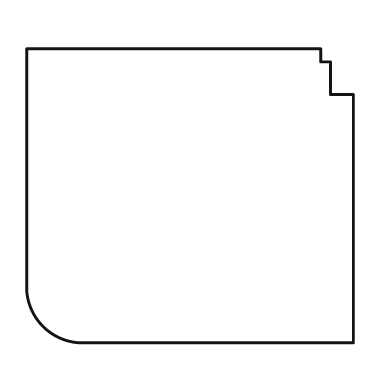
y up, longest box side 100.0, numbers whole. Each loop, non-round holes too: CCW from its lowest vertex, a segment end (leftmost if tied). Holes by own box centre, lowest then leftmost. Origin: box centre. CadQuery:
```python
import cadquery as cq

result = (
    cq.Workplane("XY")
    .moveTo(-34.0, -45.0)
    .lineTo(50.0, -45.0)
    .lineTo(50.0, 31.0)
    .lineTo(43.0, 31.0)
    .lineTo(43.0, 41.0)
    .lineTo(40.0, 41.0)
    .lineTo(40.0, 45.0)
    .lineTo(-50.0, 45.0)
    .lineTo(-50.0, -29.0)
    .threePointArc((-45.0, -40.0), (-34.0, -45.0))
    .close()
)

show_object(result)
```